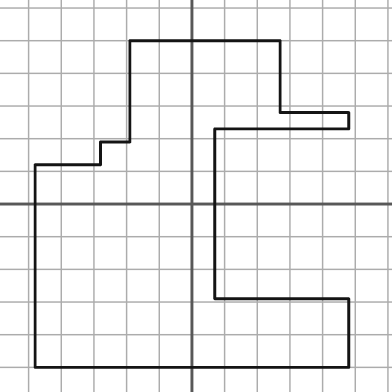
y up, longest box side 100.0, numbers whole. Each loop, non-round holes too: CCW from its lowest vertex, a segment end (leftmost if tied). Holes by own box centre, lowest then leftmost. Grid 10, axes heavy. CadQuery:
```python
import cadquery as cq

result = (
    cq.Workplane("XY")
    .moveTo(-48.0, -50.0)
    .lineTo(48.0, -50.0)
    .lineTo(48.0, -29.0)
    .lineTo(7.0, -29.0)
    .lineTo(7.0, 23.0)
    .lineTo(48.0, 23.0)
    .lineTo(48.0, 28.0)
    .lineTo(27.0, 28.0)
    .lineTo(27.0, 50.0)
    .lineTo(-19.0, 50.0)
    .lineTo(-19.0, 19.0)
    .lineTo(-28.0, 19.0)
    .lineTo(-28.0, 12.0)
    .lineTo(-48.0, 12.0)
    .close()
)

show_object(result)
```